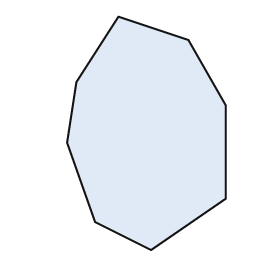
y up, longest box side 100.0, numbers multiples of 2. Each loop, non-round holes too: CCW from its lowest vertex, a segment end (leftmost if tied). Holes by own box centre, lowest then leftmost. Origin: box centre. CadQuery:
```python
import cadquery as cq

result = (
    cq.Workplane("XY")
    .moveTo(2.0, -50.0)
    .lineTo(34.0, -28.0)
    .lineTo(34.0, 12.0)
    .lineTo(18.0, 40.0)
    .lineTo(-12.0, 50.0)
    .lineTo(-30.0, 22.0)
    .lineTo(-34.0, -4.0)
    .lineTo(-22.0, -38.0)
    .close()
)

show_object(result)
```